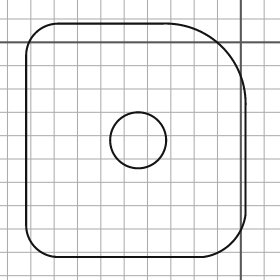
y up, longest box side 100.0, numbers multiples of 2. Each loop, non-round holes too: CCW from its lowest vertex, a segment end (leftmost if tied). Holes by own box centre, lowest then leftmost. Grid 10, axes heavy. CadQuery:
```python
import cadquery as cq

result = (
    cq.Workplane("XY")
    .moveTo(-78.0, -92.0)
    .lineTo(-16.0, -92.0)
    .threePointArc((-4.0, -86.0), (2.0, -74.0))
    .lineTo(2.0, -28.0)
    .threePointArc((-8.0, -2.0), (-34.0, 8.0))
    .lineTo(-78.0, 8.0)
    .threePointArc((-88.0, 4.0), (-92.0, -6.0))
    .lineTo(-92.0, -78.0)
    .threePointArc((-88.0, -88.0), (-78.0, -92.0))
    .close()
    .moveTo(-44.0, -42.0)
    .circle(12.0)
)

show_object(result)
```